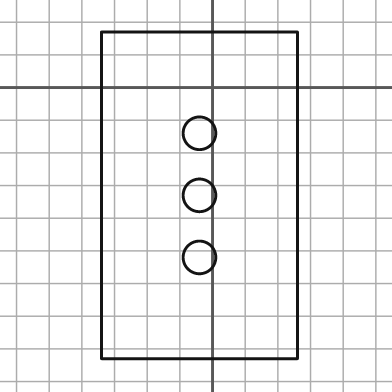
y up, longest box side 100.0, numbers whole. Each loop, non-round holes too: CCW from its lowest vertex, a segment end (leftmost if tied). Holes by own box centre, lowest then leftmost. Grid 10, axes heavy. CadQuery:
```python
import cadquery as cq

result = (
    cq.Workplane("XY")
    .moveTo(-34.0, -83.0)
    .lineTo(26.0, -83.0)
    .lineTo(26.0, 17.0)
    .lineTo(-34.0, 17.0)
    .close()
    .moveTo(-4.0, -52.0)
    .circle(5.0)
    .moveTo(-4.0, -33.0)
    .circle(5.0)
    .moveTo(-4.0, -14.0)
    .circle(5.0)
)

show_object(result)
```